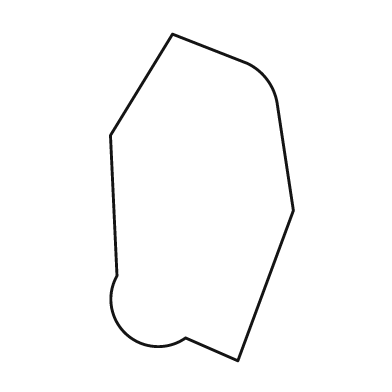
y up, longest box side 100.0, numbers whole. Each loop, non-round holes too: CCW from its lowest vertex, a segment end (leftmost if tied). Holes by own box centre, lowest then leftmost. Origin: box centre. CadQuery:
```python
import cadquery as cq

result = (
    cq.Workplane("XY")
    .moveTo(11.0, -50.0)
    .lineTo(28.0, -4.0)
    .lineTo(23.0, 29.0)
    .threePointArc((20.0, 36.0), (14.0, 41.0))
    .lineTo(-9.0, 50.0)
    .lineTo(-28.0, 19.0)
    .lineTo(-26.0, -24.0)
    .threePointArc((-23.0, -42.0), (-5.0, -43.0))
    .close()
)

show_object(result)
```